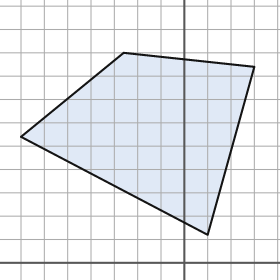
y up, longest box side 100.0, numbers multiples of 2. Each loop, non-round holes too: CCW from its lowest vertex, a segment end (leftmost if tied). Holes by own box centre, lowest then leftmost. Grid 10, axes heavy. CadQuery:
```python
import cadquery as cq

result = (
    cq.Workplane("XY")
    .moveTo(10.0, 12.0)
    .lineTo(30.0, 84.0)
    .lineTo(-26.0, 90.0)
    .lineTo(-70.0, 54.0)
    .close()
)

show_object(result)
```